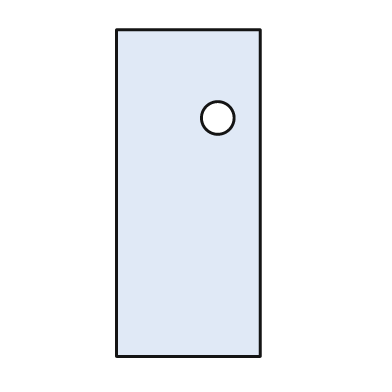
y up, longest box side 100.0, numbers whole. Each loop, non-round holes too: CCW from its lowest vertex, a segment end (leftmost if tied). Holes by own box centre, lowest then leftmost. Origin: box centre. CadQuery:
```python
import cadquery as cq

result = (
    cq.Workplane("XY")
    .moveTo(-22.0, -50.0)
    .lineTo(22.0, -50.0)
    .lineTo(22.0, 50.0)
    .lineTo(-22.0, 50.0)
    .close()
    .moveTo(9.0, 23.0)
    .circle(5.0)
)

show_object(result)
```